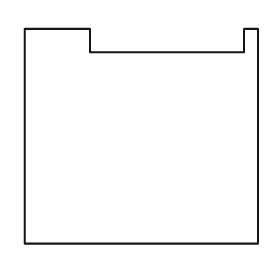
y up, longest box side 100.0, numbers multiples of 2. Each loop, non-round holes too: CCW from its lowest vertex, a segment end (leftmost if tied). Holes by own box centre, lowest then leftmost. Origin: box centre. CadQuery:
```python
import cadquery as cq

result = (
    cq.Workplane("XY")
    .moveTo(-50.0, -46.0)
    .lineTo(50.0, -46.0)
    .lineTo(50.0, 46.0)
    .lineTo(44.0, 46.0)
    .lineTo(44.0, 36.0)
    .lineTo(-22.0, 36.0)
    .lineTo(-22.0, 46.0)
    .lineTo(-50.0, 46.0)
    .close()
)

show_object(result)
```